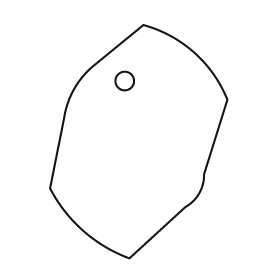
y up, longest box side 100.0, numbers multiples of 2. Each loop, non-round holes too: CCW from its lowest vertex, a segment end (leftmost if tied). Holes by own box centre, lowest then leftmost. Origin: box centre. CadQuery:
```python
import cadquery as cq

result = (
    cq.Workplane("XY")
    .moveTo(-4.0, -50.0)
    .lineTo(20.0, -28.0)
    .threePointArc((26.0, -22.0), (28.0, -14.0))
    .lineTo(38.0, 18.0)
    .threePointArc((24.0, 38.0), (2.0, 50.0))
    .lineTo(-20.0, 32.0)
    .threePointArc((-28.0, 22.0), (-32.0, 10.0))
    .lineTo(-38.0, -20.0)
    .threePointArc((-24.0, -38.0), (-4.0, -50.0))
    .close()
    .moveTo(-6.0, 26.0)
    .circle(4.0)
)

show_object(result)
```